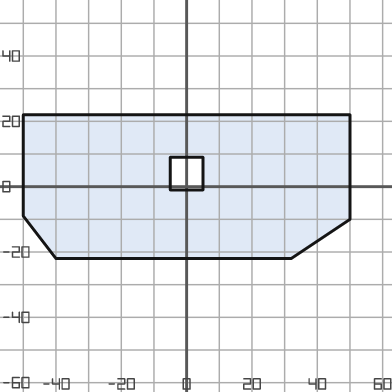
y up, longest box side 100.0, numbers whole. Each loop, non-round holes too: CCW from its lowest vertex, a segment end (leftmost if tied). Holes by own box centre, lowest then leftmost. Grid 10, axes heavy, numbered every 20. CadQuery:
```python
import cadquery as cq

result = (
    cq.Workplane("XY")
    .moveTo(-40.0, -22.0)
    .lineTo(32.0, -22.0)
    .lineTo(50.0, -10.0)
    .lineTo(50.0, 22.0)
    .lineTo(-50.0, 22.0)
    .lineTo(-50.0, -9.0)
    .close()
    .moveTo(-5.0, -1.0)
    .lineTo(5.0, -1.0)
    .lineTo(5.0, 9.0)
    .lineTo(-5.0, 9.0)
    .close()
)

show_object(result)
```